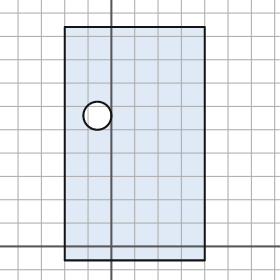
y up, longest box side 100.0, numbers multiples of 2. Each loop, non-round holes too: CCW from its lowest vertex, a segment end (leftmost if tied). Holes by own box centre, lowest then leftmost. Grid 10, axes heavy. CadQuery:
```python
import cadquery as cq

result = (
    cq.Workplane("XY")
    .moveTo(-20.0, -6.0)
    .lineTo(40.0, -6.0)
    .lineTo(40.0, 94.0)
    .lineTo(-20.0, 94.0)
    .close()
    .moveTo(-6.0, 56.0)
    .circle(6.0)
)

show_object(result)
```